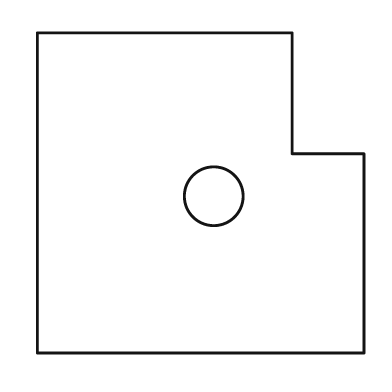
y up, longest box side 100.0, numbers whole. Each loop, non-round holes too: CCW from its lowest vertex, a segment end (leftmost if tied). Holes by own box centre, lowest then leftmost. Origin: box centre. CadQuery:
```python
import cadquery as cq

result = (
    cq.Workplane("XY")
    .moveTo(-50.0, -49.0)
    .lineTo(50.0, -49.0)
    .lineTo(50.0, 12.0)
    .lineTo(28.0, 12.0)
    .lineTo(28.0, 49.0)
    .lineTo(-50.0, 49.0)
    .close()
    .moveTo(4.0, -1.0)
    .circle(9.0)
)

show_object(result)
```